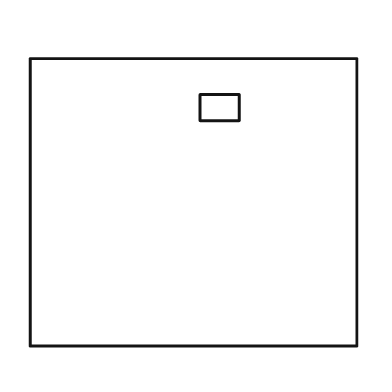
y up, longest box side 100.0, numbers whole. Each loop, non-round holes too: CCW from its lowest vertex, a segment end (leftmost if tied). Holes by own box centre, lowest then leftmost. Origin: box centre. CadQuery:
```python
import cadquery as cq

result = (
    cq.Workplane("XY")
    .moveTo(-50.0, -44.0)
    .lineTo(50.0, -44.0)
    .lineTo(50.0, 44.0)
    .lineTo(-50.0, 44.0)
    .close()
    .moveTo(2.0, 25.0)
    .lineTo(14.0, 25.0)
    .lineTo(14.0, 33.0)
    .lineTo(2.0, 33.0)
    .close()
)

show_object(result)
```